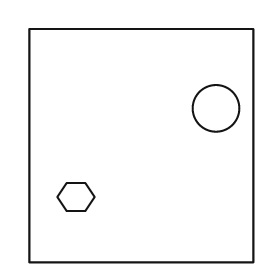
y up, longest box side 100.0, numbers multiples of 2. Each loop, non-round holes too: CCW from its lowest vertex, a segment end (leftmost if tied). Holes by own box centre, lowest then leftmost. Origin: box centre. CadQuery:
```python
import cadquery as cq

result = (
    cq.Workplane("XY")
    .moveTo(-48.0, -50.0)
    .lineTo(48.0, -50.0)
    .lineTo(48.0, 50.0)
    .lineTo(-48.0, 50.0)
    .close()
    .moveTo(-32.0, -28.0)
    .lineTo(-24.0, -28.0)
    .lineTo(-20.0, -22.0)
    .lineTo(-24.0, -16.0)
    .lineTo(-32.0, -16.0)
    .lineTo(-36.0, -22.0)
    .close()
    .moveTo(32.0, 16.0)
    .circle(10.0)
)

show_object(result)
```